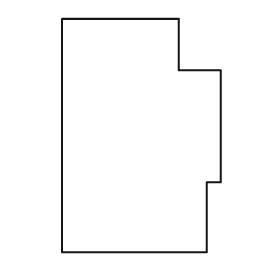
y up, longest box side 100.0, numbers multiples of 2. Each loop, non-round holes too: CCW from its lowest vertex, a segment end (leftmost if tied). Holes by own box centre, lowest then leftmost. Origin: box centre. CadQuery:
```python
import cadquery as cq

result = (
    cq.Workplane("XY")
    .moveTo(-34.0, -50.0)
    .lineTo(28.0, -50.0)
    .lineTo(28.0, -20.0)
    .lineTo(34.0, -20.0)
    .lineTo(34.0, 28.0)
    .lineTo(16.0, 28.0)
    .lineTo(16.0, 50.0)
    .lineTo(-34.0, 50.0)
    .close()
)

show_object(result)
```